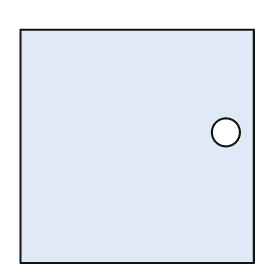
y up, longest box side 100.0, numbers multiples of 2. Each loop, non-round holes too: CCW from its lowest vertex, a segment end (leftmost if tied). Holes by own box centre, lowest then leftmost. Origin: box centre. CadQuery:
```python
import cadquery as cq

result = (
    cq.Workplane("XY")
    .moveTo(-50.0, -50.0)
    .lineTo(50.0, -50.0)
    .lineTo(50.0, 50.0)
    .lineTo(-50.0, 50.0)
    .close()
    .moveTo(38.0, 6.0)
    .circle(6.0)
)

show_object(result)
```